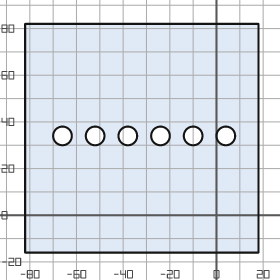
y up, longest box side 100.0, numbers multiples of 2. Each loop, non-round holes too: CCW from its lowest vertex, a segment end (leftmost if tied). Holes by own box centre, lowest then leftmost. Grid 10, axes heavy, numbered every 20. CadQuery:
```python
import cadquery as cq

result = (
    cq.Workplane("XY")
    .moveTo(-82.0, -16.0)
    .lineTo(18.0, -16.0)
    .lineTo(18.0, 82.0)
    .lineTo(-82.0, 82.0)
    .close()
    .moveTo(-66.0, 34.0)
    .circle(4.0)
    .moveTo(-52.0, 34.0)
    .circle(4.0)
    .moveTo(-38.0, 34.0)
    .circle(4.0)
    .moveTo(-24.0, 34.0)
    .circle(4.0)
    .moveTo(-10.0, 34.0)
    .circle(4.0)
    .moveTo(4.0, 34.0)
    .circle(4.0)
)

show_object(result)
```